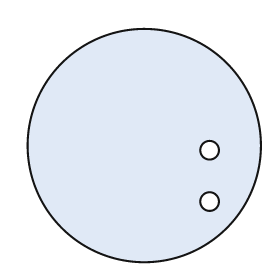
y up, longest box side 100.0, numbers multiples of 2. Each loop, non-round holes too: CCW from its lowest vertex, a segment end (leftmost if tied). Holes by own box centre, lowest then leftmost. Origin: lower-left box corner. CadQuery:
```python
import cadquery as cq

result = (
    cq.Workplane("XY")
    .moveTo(50.0, 50.0)
    .circle(50.0)
    .moveTo(78.0, 26.0)
    .circle(4.0)
    .moveTo(78.0, 48.0)
    .circle(4.0)
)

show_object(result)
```